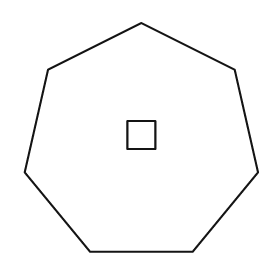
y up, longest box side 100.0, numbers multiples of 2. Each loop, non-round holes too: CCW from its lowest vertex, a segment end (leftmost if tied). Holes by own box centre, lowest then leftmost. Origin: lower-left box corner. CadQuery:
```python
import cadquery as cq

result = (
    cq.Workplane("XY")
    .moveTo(28.0, 0.0)
    .lineTo(72.0, 0.0)
    .lineTo(100.0, 34.0)
    .lineTo(90.0, 78.0)
    .lineTo(50.0, 98.0)
    .lineTo(10.0, 78.0)
    .lineTo(0.0, 34.0)
    .close()
    .moveTo(44.0, 44.0)
    .lineTo(56.0, 44.0)
    .lineTo(56.0, 56.0)
    .lineTo(44.0, 56.0)
    .close()
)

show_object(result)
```